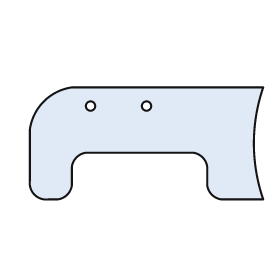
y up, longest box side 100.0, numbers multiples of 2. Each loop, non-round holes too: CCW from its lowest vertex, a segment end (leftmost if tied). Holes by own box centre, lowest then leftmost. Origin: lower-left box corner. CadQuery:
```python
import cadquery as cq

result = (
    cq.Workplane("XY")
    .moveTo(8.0, 0.0)
    .lineTo(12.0, 0.0)
    .threePointArc((16.0, 2.0), (18.0, 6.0))
    .lineTo(18.0, 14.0)
    .threePointArc((20.0, 18.0), (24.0, 20.0))
    .lineTo(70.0, 20.0)
    .threePointArc((74.0, 18.0), (76.0, 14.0))
    .lineTo(76.0, 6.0)
    .threePointArc((78.0, 2.0), (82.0, 0.0))
    .lineTo(100.0, 0.0)
    .threePointArc((96.0, 24.0), (100.0, 48.0))
    .lineTo(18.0, 48.0)
    .threePointArc((6.0, 42.0), (0.0, 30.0))
    .lineTo(0.0, 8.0)
    .threePointArc((2.0, 2.0), (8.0, 0.0))
    .close()
    .moveTo(26.0, 40.0)
    .circle(2.0)
    .moveTo(50.0, 40.0)
    .circle(2.0)
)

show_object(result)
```